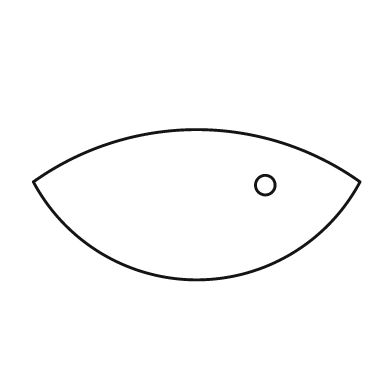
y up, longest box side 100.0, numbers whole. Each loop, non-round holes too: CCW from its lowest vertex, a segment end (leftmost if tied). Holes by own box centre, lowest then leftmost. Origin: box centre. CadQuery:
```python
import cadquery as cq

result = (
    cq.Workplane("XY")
    .moveTo(-50.0, 7.0)
    .threePointArc((0.0, -23.0), (50.0, 7.0))
    .threePointArc((0.0, 23.0), (-50.0, 7.0))
    .close()
    .moveTo(21.0, 6.0)
    .circle(3.0)
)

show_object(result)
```